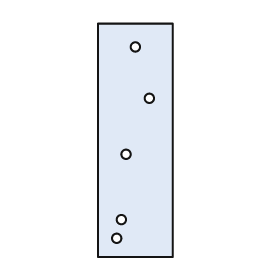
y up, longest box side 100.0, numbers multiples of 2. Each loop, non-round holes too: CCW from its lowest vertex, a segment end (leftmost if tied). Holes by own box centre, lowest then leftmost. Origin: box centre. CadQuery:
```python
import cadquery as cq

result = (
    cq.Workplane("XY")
    .moveTo(-16.0, -50.0)
    .lineTo(16.0, -50.0)
    .lineTo(16.0, 50.0)
    .lineTo(-16.0, 50.0)
    .close()
    .moveTo(-8.0, -42.0)
    .circle(2.0)
    .moveTo(-6.0, -34.0)
    .circle(2.0)
    .moveTo(-4.0, -6.0)
    .circle(2.0)
    .moveTo(6.0, 18.0)
    .circle(2.0)
    .moveTo(0.0, 40.0)
    .circle(2.0)
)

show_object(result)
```